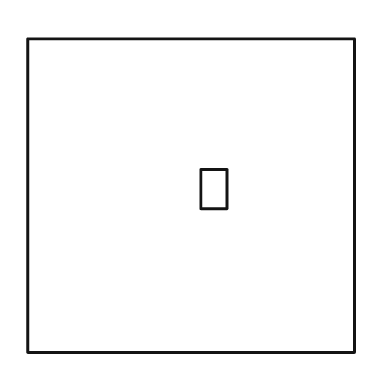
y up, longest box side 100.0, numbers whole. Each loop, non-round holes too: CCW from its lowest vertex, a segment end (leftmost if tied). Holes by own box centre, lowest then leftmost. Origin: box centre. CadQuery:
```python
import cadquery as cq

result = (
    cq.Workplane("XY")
    .moveTo(-50.0, -48.0)
    .lineTo(50.0, -48.0)
    .lineTo(50.0, 48.0)
    .lineTo(-50.0, 48.0)
    .close()
    .moveTo(3.0, -4.0)
    .lineTo(11.0, -4.0)
    .lineTo(11.0, 8.0)
    .lineTo(3.0, 8.0)
    .close()
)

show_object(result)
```